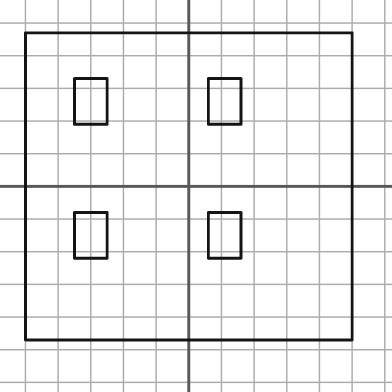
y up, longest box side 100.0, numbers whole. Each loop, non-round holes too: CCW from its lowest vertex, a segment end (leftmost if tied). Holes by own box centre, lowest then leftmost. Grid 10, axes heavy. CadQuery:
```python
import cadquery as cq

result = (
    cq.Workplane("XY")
    .moveTo(-50.0, -47.0)
    .lineTo(50.0, -47.0)
    .lineTo(50.0, 47.0)
    .lineTo(-50.0, 47.0)
    .close()
    .moveTo(-35.0, -22.0)
    .lineTo(-25.0, -22.0)
    .lineTo(-25.0, -8.0)
    .lineTo(-35.0, -8.0)
    .close()
    .moveTo(6.0, -22.0)
    .lineTo(16.0, -22.0)
    .lineTo(16.0, -8.0)
    .lineTo(6.0, -8.0)
    .close()
    .moveTo(-35.0, 19.0)
    .lineTo(-25.0, 19.0)
    .lineTo(-25.0, 33.0)
    .lineTo(-35.0, 33.0)
    .close()
    .moveTo(6.0, 19.0)
    .lineTo(16.0, 19.0)
    .lineTo(16.0, 33.0)
    .lineTo(6.0, 33.0)
    .close()
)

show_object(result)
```